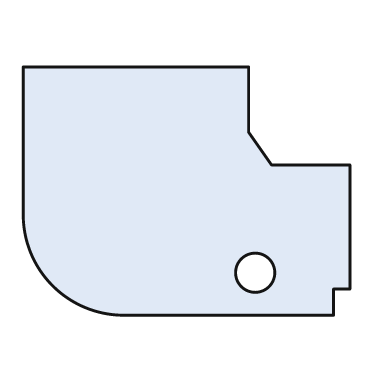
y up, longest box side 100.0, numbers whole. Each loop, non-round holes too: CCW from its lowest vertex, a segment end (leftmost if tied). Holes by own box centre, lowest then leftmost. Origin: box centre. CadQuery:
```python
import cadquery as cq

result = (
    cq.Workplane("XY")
    .moveTo(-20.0, -38.0)
    .lineTo(45.0, -38.0)
    .lineTo(45.0, -30.0)
    .lineTo(50.0, -30.0)
    .lineTo(50.0, 8.0)
    .lineTo(26.0, 8.0)
    .lineTo(19.0, 18.0)
    .lineTo(19.0, 38.0)
    .lineTo(-50.0, 38.0)
    .lineTo(-50.0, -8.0)
    .threePointArc((-41.0, -29.0), (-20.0, -38.0))
    .close()
    .moveTo(21.0, -25.0)
    .circle(6.0)
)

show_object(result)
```